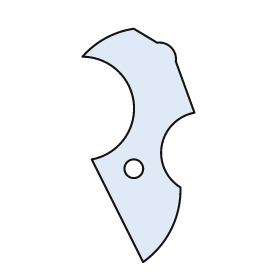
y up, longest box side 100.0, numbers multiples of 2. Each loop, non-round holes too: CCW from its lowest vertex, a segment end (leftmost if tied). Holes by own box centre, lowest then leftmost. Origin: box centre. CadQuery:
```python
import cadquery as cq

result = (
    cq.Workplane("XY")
    .moveTo(2.0, -50.0)
    .threePointArc((14.0, -36.0), (18.0, -18.0))
    .threePointArc((10.0, 0.0), (24.0, 14.0))
    .lineTo(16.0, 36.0)
    .threePointArc((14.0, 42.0), (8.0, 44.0))
    .lineTo(-2.0, 50.0)
    .threePointArc((-14.0, 46.0), (-24.0, 38.0))
    .threePointArc((-2.0, 18.0), (-20.0, -6.0))
    .close()
    .moveTo(-2.0, -10.0)
    .circle(4.0)
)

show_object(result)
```